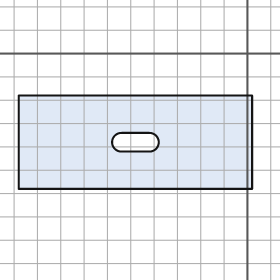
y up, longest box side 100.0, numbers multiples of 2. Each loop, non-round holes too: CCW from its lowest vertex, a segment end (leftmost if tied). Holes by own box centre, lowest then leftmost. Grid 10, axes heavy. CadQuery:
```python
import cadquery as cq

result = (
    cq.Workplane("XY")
    .moveTo(-98.0, -58.0)
    .lineTo(2.0, -58.0)
    .lineTo(2.0, -18.0)
    .lineTo(-98.0, -18.0)
    .close()
    .moveTo(-54.0, -42.0)
    .lineTo(-42.0, -42.0)
    .threePointArc((-38.0, -38.0), (-42.0, -34.0))
    .lineTo(-54.0, -34.0)
    .threePointArc((-58.0, -38.0), (-54.0, -42.0))
    .close()
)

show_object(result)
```